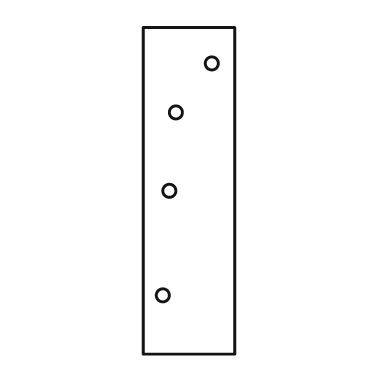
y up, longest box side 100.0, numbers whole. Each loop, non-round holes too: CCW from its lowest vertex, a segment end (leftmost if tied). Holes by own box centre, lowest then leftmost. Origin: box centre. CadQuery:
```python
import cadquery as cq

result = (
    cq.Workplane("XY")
    .moveTo(-14.0, -50.0)
    .lineTo(14.0, -50.0)
    .lineTo(14.0, 50.0)
    .lineTo(-14.0, 50.0)
    .close()
    .moveTo(-8.0, -32.0)
    .circle(2.0)
    .moveTo(-6.0, 0.0)
    .circle(2.0)
    .moveTo(-4.0, 24.0)
    .circle(2.0)
    .moveTo(7.0, 39.0)
    .circle(2.0)
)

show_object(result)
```